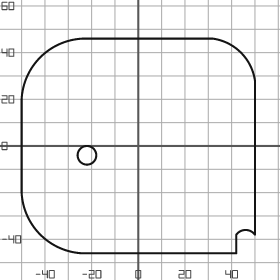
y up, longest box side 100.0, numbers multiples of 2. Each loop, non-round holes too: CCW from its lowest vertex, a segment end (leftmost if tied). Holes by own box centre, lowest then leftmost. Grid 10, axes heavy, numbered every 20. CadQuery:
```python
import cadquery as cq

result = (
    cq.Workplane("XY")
    .moveTo(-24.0, -46.0)
    .lineTo(42.0, -46.0)
    .lineTo(42.0, -38.0)
    .threePointArc((46.0, -36.0), (50.0, -38.0))
    .lineTo(50.0, 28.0)
    .threePointArc((44.0, 40.0), (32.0, 46.0))
    .lineTo(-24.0, 46.0)
    .threePointArc((-42.0, 38.0), (-50.0, 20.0))
    .lineTo(-50.0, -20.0)
    .threePointArc((-42.0, -38.0), (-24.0, -46.0))
    .close()
    .moveTo(-22.0, -4.0)
    .circle(4.0)
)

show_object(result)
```